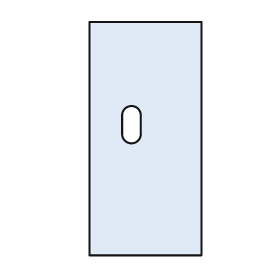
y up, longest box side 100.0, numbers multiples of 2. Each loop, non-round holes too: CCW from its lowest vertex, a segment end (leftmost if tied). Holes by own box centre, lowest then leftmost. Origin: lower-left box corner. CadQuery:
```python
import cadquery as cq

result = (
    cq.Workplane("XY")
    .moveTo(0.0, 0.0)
    .lineTo(48.0, 0.0)
    .lineTo(48.0, 100.0)
    .lineTo(0.0, 100.0)
    .close()
    .moveTo(14.0, 52.0)
    .threePointArc((18.0, 48.0), (22.0, 52.0))
    .lineTo(22.0, 60.0)
    .threePointArc((18.0, 64.0), (14.0, 60.0))
    .close()
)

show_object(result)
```